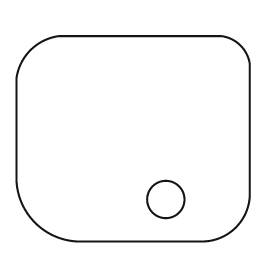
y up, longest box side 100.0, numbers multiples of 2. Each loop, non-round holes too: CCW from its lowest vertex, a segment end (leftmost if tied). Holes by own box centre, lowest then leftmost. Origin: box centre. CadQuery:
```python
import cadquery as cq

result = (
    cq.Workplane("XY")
    .moveTo(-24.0, -44.0)
    .lineTo(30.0, -44.0)
    .threePointArc((44.0, -38.0), (50.0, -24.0))
    .lineTo(50.0, 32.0)
    .threePointArc((46.0, 40.0), (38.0, 44.0))
    .lineTo(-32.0, 44.0)
    .threePointArc((-44.0, 38.0), (-50.0, 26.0))
    .lineTo(-50.0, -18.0)
    .threePointArc((-42.0, -36.0), (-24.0, -44.0))
    .close()
    .moveTo(14.0, -26.0)
    .circle(8.0)
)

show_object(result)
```